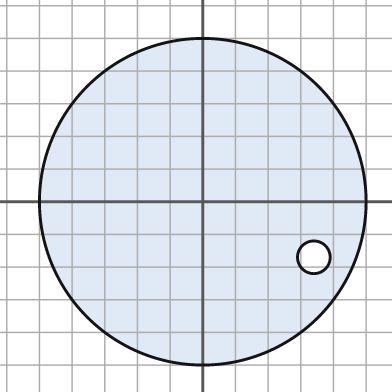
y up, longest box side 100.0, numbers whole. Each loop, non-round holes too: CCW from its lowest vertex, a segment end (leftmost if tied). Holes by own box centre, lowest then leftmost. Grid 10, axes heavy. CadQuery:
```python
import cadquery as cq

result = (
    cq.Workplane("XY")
    .moveTo(0.0, 0.0)
    .circle(50.0)
    .moveTo(34.0, -17.0)
    .circle(5.0)
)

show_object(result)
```